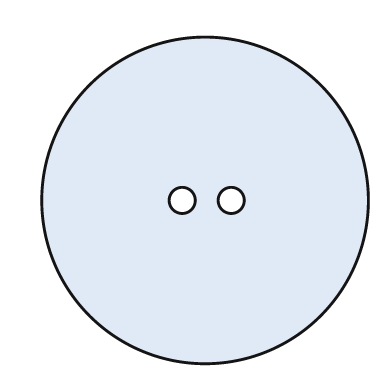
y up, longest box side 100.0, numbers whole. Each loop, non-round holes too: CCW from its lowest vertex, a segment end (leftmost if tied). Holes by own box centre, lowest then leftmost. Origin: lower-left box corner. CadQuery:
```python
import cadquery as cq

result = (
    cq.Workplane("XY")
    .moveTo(50.0, 50.0)
    .circle(50.0)
    .moveTo(43.0, 50.0)
    .circle(4.0)
    .moveTo(58.0, 50.0)
    .circle(4.0)
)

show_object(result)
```